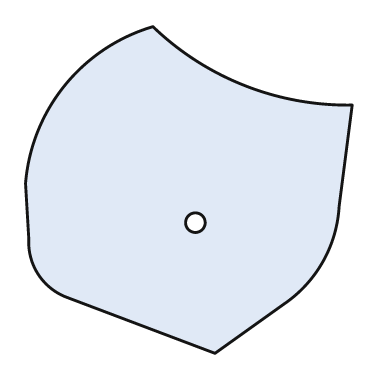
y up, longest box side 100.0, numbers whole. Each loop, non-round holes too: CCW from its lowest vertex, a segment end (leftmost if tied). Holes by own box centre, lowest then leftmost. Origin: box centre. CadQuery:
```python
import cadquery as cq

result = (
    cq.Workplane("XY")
    .moveTo(8.0, -50.0)
    .lineTo(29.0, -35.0)
    .threePointArc((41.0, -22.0), (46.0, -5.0))
    .lineTo(50.0, 26.0)
    .threePointArc((17.0, 32.0), (-11.0, 50.0))
    .threePointArc((-38.0, 32.0), (-50.0, 2.0))
    .lineTo(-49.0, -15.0)
    .threePointArc((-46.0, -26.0), (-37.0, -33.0))
    .close()
    .moveTo(2.0, -10.0)
    .circle(3.0)
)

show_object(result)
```